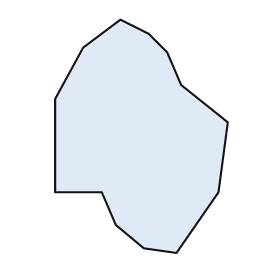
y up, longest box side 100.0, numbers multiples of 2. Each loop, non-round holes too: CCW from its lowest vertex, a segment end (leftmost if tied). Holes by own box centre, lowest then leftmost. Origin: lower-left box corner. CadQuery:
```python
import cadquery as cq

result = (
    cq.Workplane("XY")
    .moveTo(52.0, 0.0)
    .lineTo(70.0, 26.0)
    .lineTo(74.0, 56.0)
    .lineTo(54.0, 72.0)
    .lineTo(48.0, 86.0)
    .lineTo(40.0, 94.0)
    .lineTo(28.0, 100.0)
    .lineTo(12.0, 88.0)
    .lineTo(0.0, 66.0)
    .lineTo(0.0, 26.0)
    .lineTo(20.0, 26.0)
    .lineTo(26.0, 12.0)
    .lineTo(38.0, 2.0)
    .close()
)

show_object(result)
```